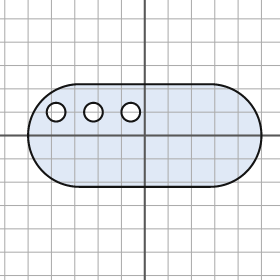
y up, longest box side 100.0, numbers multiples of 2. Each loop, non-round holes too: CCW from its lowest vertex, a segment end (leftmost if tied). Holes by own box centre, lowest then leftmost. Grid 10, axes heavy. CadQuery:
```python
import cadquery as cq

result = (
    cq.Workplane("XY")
    .moveTo(-28.0, -22.0)
    .lineTo(28.0, -22.0)
    .threePointArc((50.0, 0.0), (28.0, 22.0))
    .lineTo(-28.0, 22.0)
    .threePointArc((-50.0, 0.0), (-28.0, -22.0))
    .close()
    .moveTo(-38.0, 10.0)
    .circle(4.0)
    .moveTo(-22.0, 10.0)
    .circle(4.0)
    .moveTo(-6.0, 10.0)
    .circle(4.0)
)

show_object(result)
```